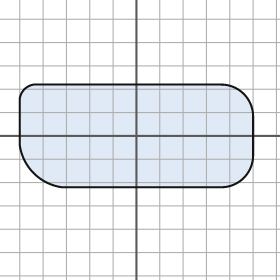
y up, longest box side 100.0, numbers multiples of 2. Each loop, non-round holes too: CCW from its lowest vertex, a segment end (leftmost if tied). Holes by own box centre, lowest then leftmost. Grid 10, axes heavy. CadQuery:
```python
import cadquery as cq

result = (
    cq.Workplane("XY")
    .moveTo(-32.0, -22.0)
    .lineTo(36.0, -22.0)
    .threePointArc((46.0, -18.0), (50.0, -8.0))
    .lineTo(50.0, 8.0)
    .threePointArc((46.0, 18.0), (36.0, 22.0))
    .lineTo(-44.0, 22.0)
    .threePointArc((-48.0, 20.0), (-50.0, 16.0))
    .lineTo(-50.0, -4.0)
    .threePointArc((-44.0, -16.0), (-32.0, -22.0))
    .close()
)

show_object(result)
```